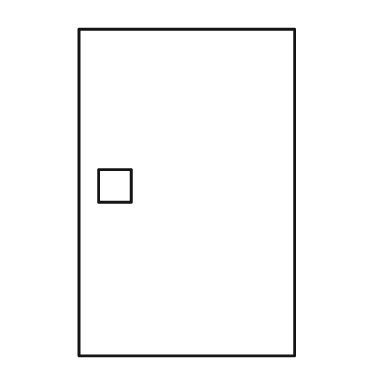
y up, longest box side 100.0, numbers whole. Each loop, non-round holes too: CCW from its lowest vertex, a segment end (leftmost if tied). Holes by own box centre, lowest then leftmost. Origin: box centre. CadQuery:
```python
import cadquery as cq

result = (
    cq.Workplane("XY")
    .moveTo(-33.0, -50.0)
    .lineTo(33.0, -50.0)
    .lineTo(33.0, 50.0)
    .lineTo(-33.0, 50.0)
    .close()
    .moveTo(-27.0, -3.0)
    .lineTo(-17.0, -3.0)
    .lineTo(-17.0, 7.0)
    .lineTo(-27.0, 7.0)
    .close()
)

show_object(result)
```